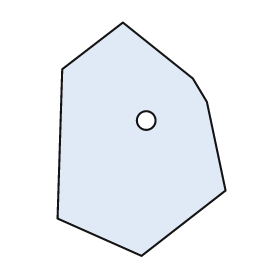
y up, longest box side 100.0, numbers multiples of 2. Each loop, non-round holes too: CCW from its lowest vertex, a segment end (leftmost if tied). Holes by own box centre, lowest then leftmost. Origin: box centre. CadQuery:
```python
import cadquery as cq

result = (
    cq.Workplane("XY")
    .moveTo(0.0, -50.0)
    .lineTo(36.0, -22.0)
    .lineTo(28.0, 16.0)
    .lineTo(22.0, 26.0)
    .lineTo(-8.0, 50.0)
    .lineTo(-34.0, 30.0)
    .lineTo(-36.0, -34.0)
    .close()
    .moveTo(2.0, 8.0)
    .circle(4.0)
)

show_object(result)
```